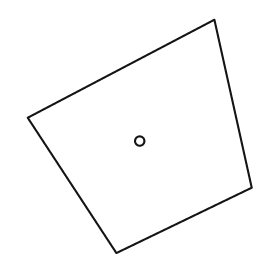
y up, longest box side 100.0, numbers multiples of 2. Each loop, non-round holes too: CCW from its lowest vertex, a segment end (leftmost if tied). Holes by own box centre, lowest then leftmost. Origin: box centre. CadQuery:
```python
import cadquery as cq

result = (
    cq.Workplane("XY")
    .moveTo(-10.0, -50.0)
    .lineTo(48.0, -22.0)
    .lineTo(32.0, 50.0)
    .lineTo(-48.0, 8.0)
    .close()
    .moveTo(0.0, -2.0)
    .circle(2.0)
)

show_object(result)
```